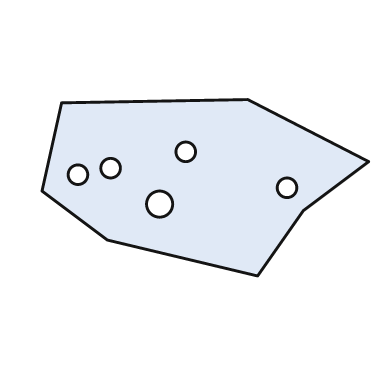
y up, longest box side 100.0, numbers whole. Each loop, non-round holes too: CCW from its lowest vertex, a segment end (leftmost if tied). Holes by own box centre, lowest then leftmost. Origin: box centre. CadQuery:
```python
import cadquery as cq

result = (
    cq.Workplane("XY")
    .moveTo(16.0, -27.0)
    .lineTo(30.0, -7.0)
    .lineTo(50.0, 8.0)
    .lineTo(13.0, 27.0)
    .lineTo(-44.0, 26.0)
    .lineTo(-50.0, -1.0)
    .lineTo(-30.0, -16.0)
    .close()
    .moveTo(-14.0, -5.0)
    .circle(4.0)
    .moveTo(25.0, 0.0)
    .circle(3.0)
    .moveTo(-39.0, 4.0)
    .circle(3.0)
    .moveTo(-29.0, 6.0)
    .circle(3.0)
    .moveTo(-6.0, 11.0)
    .circle(3.0)
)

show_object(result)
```